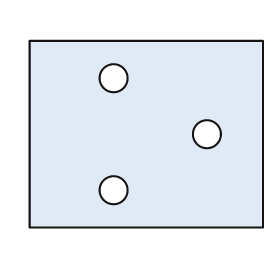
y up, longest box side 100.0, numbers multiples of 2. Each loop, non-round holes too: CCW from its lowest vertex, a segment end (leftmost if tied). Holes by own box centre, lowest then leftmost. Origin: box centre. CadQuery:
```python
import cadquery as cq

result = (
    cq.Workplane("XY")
    .moveTo(-50.0, -40.0)
    .lineTo(50.0, -40.0)
    .lineTo(50.0, 40.0)
    .lineTo(-50.0, 40.0)
    .close()
    .moveTo(-14.0, -24.0)
    .circle(6.0)
    .moveTo(26.0, 0.0)
    .circle(6.0)
    .moveTo(-14.0, 24.0)
    .circle(6.0)
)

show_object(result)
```